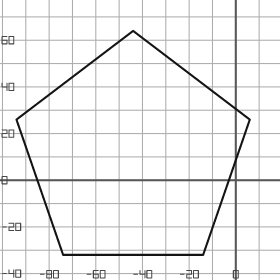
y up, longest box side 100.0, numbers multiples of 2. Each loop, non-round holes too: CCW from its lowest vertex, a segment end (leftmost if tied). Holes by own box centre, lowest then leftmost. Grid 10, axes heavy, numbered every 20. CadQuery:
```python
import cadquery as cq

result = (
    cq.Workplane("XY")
    .moveTo(-74.0, -32.0)
    .lineTo(-14.0, -32.0)
    .lineTo(6.0, 26.0)
    .lineTo(-44.0, 64.0)
    .lineTo(-94.0, 26.0)
    .close()
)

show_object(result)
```